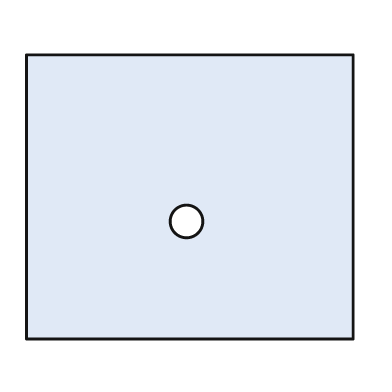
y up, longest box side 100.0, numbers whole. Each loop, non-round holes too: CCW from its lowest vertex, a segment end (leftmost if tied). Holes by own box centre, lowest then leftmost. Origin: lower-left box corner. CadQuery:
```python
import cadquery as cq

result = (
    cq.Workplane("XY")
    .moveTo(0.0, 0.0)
    .lineTo(100.0, 0.0)
    .lineTo(100.0, 87.0)
    .lineTo(0.0, 87.0)
    .close()
    .moveTo(49.0, 36.0)
    .circle(5.0)
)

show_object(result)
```